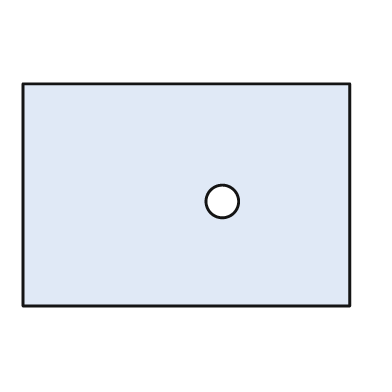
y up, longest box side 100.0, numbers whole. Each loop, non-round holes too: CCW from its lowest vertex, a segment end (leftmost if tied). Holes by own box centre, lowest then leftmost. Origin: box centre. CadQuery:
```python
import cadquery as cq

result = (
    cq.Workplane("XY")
    .moveTo(-50.0, -34.0)
    .lineTo(50.0, -34.0)
    .lineTo(50.0, 34.0)
    .lineTo(-50.0, 34.0)
    .close()
    .moveTo(11.0, -2.0)
    .circle(5.0)
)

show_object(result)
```